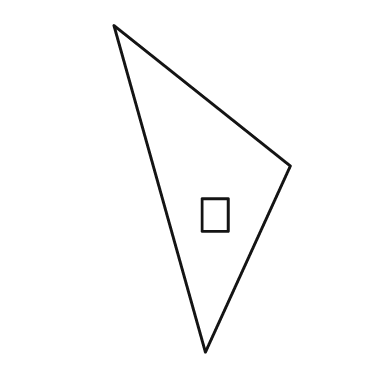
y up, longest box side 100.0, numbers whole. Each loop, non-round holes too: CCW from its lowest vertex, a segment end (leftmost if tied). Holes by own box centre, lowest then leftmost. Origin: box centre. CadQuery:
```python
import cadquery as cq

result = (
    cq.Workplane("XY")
    .moveTo(1.0, -50.0)
    .lineTo(27.0, 7.0)
    .lineTo(-27.0, 50.0)
    .close()
    .moveTo(0.0, -13.0)
    .lineTo(8.0, -13.0)
    .lineTo(8.0, -3.0)
    .lineTo(0.0, -3.0)
    .close()
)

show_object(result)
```